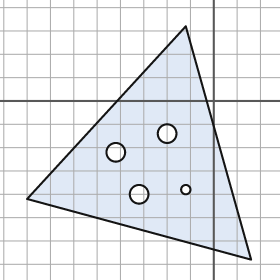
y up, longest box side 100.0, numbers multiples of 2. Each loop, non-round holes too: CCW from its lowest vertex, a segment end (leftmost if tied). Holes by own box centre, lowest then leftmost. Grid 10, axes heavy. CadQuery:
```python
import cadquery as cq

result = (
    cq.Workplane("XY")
    .moveTo(16.0, -68.0)
    .lineTo(-12.0, 32.0)
    .lineTo(-80.0, -42.0)
    .close()
    .moveTo(-32.0, -40.0)
    .circle(4.0)
    .moveTo(-12.0, -38.0)
    .circle(2.0)
    .moveTo(-42.0, -22.0)
    .circle(4.0)
    .moveTo(-20.0, -14.0)
    .circle(4.0)
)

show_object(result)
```